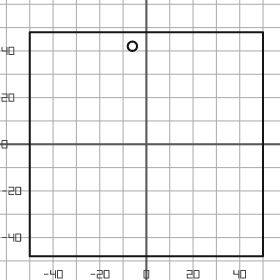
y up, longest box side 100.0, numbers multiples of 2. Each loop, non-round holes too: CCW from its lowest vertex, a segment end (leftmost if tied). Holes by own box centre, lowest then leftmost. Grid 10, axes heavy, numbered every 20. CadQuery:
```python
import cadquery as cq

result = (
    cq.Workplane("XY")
    .moveTo(-50.0, -48.0)
    .lineTo(50.0, -48.0)
    .lineTo(50.0, 48.0)
    .lineTo(-50.0, 48.0)
    .close()
    .moveTo(-6.0, 42.0)
    .circle(2.0)
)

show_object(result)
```